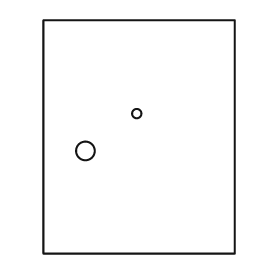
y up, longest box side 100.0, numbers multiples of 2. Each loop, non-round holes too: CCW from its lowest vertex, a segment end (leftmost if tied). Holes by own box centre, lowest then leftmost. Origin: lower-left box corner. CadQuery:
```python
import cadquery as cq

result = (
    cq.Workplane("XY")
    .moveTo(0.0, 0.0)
    .lineTo(82.0, 0.0)
    .lineTo(82.0, 100.0)
    .lineTo(0.0, 100.0)
    .close()
    .moveTo(18.0, 44.0)
    .circle(4.0)
    .moveTo(40.0, 60.0)
    .circle(2.0)
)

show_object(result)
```